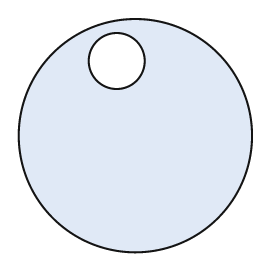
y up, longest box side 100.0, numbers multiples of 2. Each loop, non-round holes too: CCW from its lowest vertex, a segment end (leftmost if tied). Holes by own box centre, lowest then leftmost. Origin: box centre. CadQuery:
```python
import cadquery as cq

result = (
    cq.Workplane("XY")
    .moveTo(0.0, 0.0)
    .circle(50.0)
    .moveTo(-8.0, 32.0)
    .circle(12.0)
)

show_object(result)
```